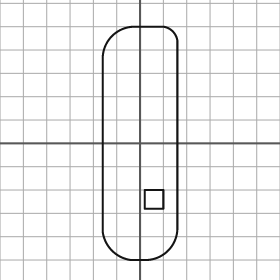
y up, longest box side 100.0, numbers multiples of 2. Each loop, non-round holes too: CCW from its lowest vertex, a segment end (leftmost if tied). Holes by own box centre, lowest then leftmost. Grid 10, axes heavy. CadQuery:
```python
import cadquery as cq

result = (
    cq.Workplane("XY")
    .moveTo(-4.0, -50.0)
    .lineTo(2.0, -50.0)
    .threePointArc((12.0, -46.0), (16.0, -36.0))
    .lineTo(16.0, 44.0)
    .threePointArc((14.0, 48.0), (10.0, 50.0))
    .lineTo(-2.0, 50.0)
    .threePointArc((-12.0, 46.0), (-16.0, 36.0))
    .lineTo(-16.0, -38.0)
    .threePointArc((-12.0, -46.0), (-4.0, -50.0))
    .close()
    .moveTo(2.0, -28.0)
    .lineTo(10.0, -28.0)
    .lineTo(10.0, -20.0)
    .lineTo(2.0, -20.0)
    .close()
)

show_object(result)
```